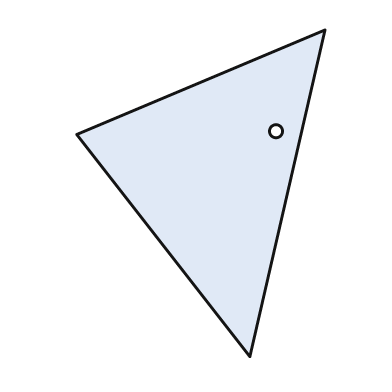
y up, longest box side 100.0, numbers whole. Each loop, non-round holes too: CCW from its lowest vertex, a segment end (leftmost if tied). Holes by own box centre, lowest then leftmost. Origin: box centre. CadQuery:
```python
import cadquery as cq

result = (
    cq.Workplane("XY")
    .moveTo(15.0, -50.0)
    .lineTo(38.0, 50.0)
    .lineTo(-38.0, 18.0)
    .close()
    .moveTo(23.0, 19.0)
    .circle(2.0)
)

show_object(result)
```